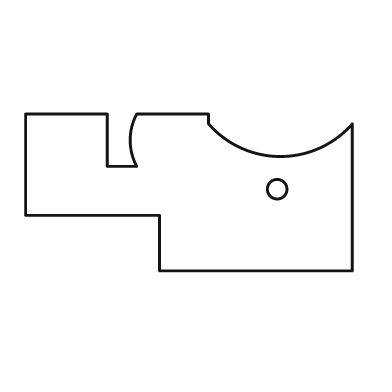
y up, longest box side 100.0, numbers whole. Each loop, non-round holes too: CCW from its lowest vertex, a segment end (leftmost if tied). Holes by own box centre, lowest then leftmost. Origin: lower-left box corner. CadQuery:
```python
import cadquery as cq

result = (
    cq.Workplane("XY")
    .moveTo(41.0, 0.0)
    .lineTo(100.0, 0.0)
    .lineTo(100.0, 45.0)
    .threePointArc((78.0, 35.0), (56.0, 45.0))
    .lineTo(56.0, 48.0)
    .lineTo(34.0, 48.0)
    .threePointArc((32.0, 40.0), (34.0, 32.0))
    .lineTo(25.0, 32.0)
    .lineTo(25.0, 48.0)
    .lineTo(0.0, 48.0)
    .lineTo(0.0, 17.0)
    .lineTo(41.0, 17.0)
    .close()
    .moveTo(77.0, 25.0)
    .circle(3.0)
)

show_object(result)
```